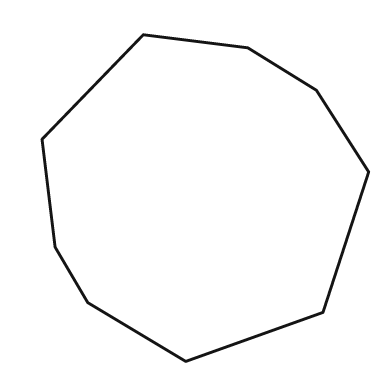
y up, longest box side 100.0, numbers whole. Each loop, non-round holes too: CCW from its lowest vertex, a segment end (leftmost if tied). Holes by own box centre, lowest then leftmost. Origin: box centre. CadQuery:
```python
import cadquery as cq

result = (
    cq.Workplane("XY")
    .moveTo(-6.0, -50.0)
    .lineTo(36.0, -35.0)
    .lineTo(50.0, 8.0)
    .lineTo(34.0, 33.0)
    .lineTo(13.0, 46.0)
    .lineTo(-19.0, 50.0)
    .lineTo(-50.0, 18.0)
    .lineTo(-46.0, -15.0)
    .lineTo(-36.0, -32.0)
    .close()
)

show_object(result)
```